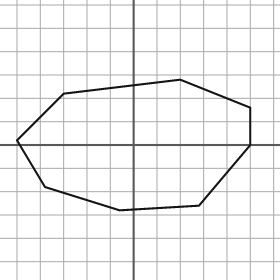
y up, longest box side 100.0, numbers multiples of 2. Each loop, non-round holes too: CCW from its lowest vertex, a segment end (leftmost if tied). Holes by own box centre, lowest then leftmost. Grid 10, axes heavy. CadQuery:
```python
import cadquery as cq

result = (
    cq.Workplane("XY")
    .moveTo(-6.0, -28.0)
    .lineTo(28.0, -26.0)
    .lineTo(50.0, 0.0)
    .lineTo(50.0, 16.0)
    .lineTo(20.0, 28.0)
    .lineTo(-30.0, 22.0)
    .lineTo(-50.0, 2.0)
    .lineTo(-38.0, -18.0)
    .close()
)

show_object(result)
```